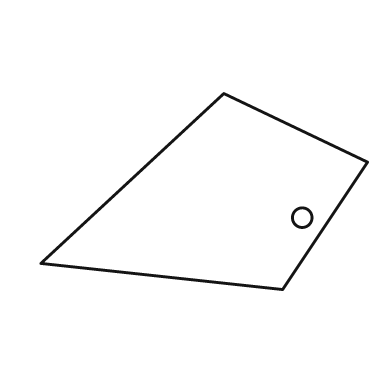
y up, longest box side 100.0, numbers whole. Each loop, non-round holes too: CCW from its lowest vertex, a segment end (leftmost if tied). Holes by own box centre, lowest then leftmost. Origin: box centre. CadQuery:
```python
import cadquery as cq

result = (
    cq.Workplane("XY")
    .moveTo(24.0, -30.0)
    .lineTo(50.0, 9.0)
    .lineTo(6.0, 30.0)
    .lineTo(-50.0, -22.0)
    .close()
    .moveTo(30.0, -8.0)
    .circle(3.0)
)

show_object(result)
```